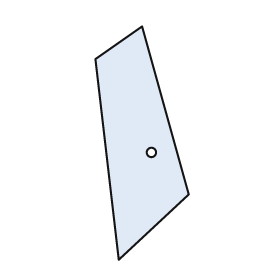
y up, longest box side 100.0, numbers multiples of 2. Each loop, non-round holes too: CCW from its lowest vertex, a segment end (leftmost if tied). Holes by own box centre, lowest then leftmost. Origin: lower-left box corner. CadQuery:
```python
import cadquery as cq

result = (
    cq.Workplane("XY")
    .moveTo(10.0, 0.0)
    .lineTo(40.0, 28.0)
    .lineTo(20.0, 100.0)
    .lineTo(0.0, 86.0)
    .close()
    .moveTo(24.0, 46.0)
    .circle(2.0)
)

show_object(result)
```